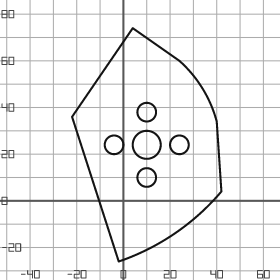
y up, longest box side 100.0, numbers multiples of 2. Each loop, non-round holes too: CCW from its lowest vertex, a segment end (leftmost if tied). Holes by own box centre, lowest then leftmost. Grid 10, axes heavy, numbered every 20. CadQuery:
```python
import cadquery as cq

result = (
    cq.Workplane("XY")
    .moveTo(-2.0, -26.0)
    .threePointArc((22.0, -14.0), (42.0, 4.0))
    .lineTo(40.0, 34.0)
    .threePointArc((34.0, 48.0), (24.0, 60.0))
    .lineTo(4.0, 74.0)
    .lineTo(-22.0, 36.0)
    .close()
    .moveTo(10.0, 10.0)
    .circle(4.0)
    .moveTo(-4.0, 24.0)
    .circle(4.0)
    .moveTo(10.0, 24.0)
    .circle(6.0)
    .moveTo(24.0, 24.0)
    .circle(4.0)
    .moveTo(10.0, 38.0)
    .circle(4.0)
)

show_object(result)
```